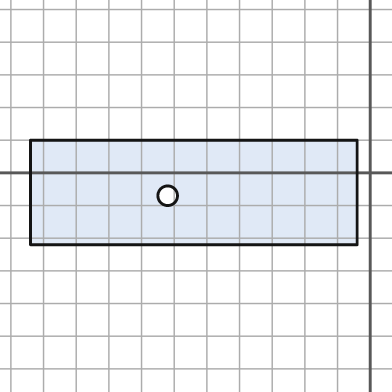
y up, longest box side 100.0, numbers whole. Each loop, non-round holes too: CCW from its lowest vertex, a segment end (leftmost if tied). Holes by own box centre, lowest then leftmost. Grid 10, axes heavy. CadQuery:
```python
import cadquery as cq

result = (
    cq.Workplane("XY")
    .moveTo(-104.0, -22.0)
    .lineTo(-4.0, -22.0)
    .lineTo(-4.0, 10.0)
    .lineTo(-104.0, 10.0)
    .close()
    .moveTo(-62.0, -7.0)
    .circle(3.0)
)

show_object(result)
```